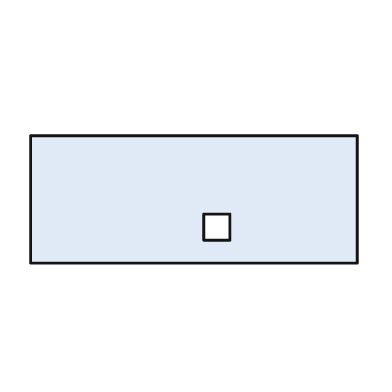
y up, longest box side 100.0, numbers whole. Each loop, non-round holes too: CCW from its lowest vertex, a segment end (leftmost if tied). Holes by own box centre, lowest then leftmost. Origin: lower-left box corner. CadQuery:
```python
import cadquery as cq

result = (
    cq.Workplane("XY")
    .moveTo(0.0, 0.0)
    .lineTo(100.0, 0.0)
    .lineTo(100.0, 39.0)
    .lineTo(0.0, 39.0)
    .close()
    .moveTo(53.0, 7.0)
    .lineTo(61.0, 7.0)
    .lineTo(61.0, 15.0)
    .lineTo(53.0, 15.0)
    .close()
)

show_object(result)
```